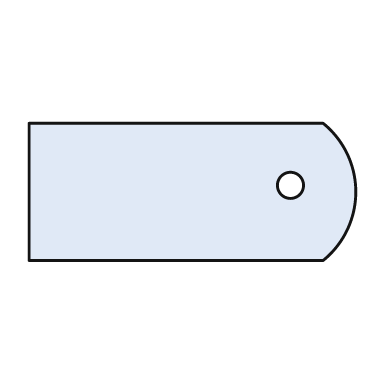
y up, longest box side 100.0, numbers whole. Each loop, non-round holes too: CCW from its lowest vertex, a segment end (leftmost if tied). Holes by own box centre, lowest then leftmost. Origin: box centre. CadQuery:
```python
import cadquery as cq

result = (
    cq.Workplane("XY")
    .moveTo(-50.0, -21.0)
    .lineTo(40.0, -21.0)
    .threePointArc((50.0, 0.0), (40.0, 21.0))
    .lineTo(-50.0, 21.0)
    .close()
    .moveTo(30.0, 2.0)
    .circle(4.0)
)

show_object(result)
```